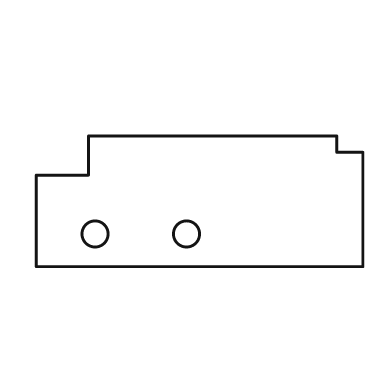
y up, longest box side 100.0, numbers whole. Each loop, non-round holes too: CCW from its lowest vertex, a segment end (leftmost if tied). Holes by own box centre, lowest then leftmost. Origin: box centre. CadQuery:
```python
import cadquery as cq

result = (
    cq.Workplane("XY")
    .moveTo(-50.0, -20.0)
    .lineTo(50.0, -20.0)
    .lineTo(50.0, 15.0)
    .lineTo(42.0, 15.0)
    .lineTo(42.0, 20.0)
    .lineTo(-34.0, 20.0)
    .lineTo(-34.0, 8.0)
    .lineTo(-50.0, 8.0)
    .close()
    .moveTo(-32.0, -10.0)
    .circle(4.0)
    .moveTo(-4.0, -10.0)
    .circle(4.0)
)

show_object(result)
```